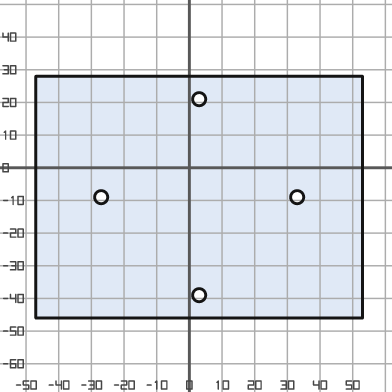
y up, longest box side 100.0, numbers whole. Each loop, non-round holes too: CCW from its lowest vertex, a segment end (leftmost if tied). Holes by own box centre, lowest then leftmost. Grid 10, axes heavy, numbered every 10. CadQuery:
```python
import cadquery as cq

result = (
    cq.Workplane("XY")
    .moveTo(-47.0, -46.0)
    .lineTo(53.0, -46.0)
    .lineTo(53.0, 28.0)
    .lineTo(-47.0, 28.0)
    .close()
    .moveTo(3.0, -39.0)
    .circle(2.0)
    .moveTo(-27.0, -9.0)
    .circle(2.0)
    .moveTo(33.0, -9.0)
    .circle(2.0)
    .moveTo(3.0, 21.0)
    .circle(2.0)
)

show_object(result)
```